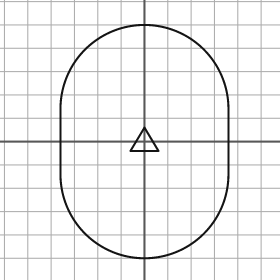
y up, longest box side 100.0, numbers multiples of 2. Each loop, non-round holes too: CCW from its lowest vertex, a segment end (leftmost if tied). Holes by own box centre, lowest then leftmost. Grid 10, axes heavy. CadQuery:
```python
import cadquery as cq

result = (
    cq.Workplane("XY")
    .moveTo(-36.0, -14.0)
    .threePointArc((0.0, -50.0), (36.0, -14.0))
    .lineTo(36.0, 14.0)
    .threePointArc((0.0, 50.0), (-36.0, 14.0))
    .close()
    .moveTo(-6.0, -4.0)
    .lineTo(6.0, -4.0)
    .lineTo(0.0, 6.0)
    .close()
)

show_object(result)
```